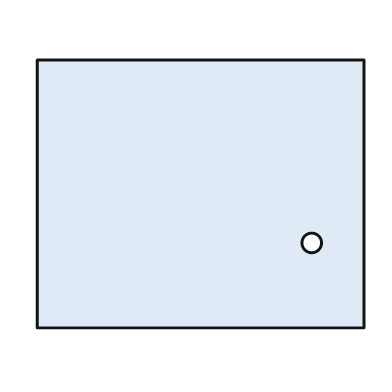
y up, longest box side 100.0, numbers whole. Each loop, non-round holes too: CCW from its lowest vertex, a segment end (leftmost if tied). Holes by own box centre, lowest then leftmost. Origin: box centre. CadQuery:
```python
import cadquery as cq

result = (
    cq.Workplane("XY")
    .moveTo(-50.0, -41.0)
    .lineTo(50.0, -41.0)
    .lineTo(50.0, 41.0)
    .lineTo(-50.0, 41.0)
    .close()
    .moveTo(34.0, -15.0)
    .circle(3.0)
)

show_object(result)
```